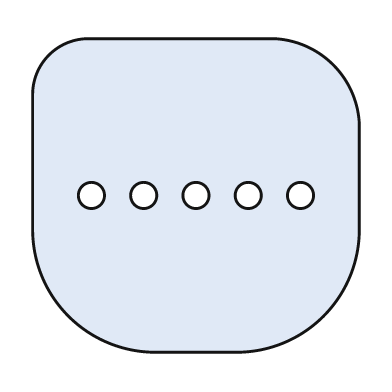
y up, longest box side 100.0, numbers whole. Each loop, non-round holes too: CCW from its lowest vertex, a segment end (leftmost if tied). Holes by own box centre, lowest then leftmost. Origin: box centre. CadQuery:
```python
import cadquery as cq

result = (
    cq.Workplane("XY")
    .moveTo(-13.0, -48.0)
    .lineTo(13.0, -48.0)
    .threePointArc((39.0, -37.0), (50.0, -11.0))
    .lineTo(50.0, 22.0)
    .threePointArc((42.0, 40.0), (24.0, 48.0))
    .lineTo(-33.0, 48.0)
    .threePointArc((-45.0, 43.0), (-50.0, 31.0))
    .lineTo(-50.0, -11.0)
    .threePointArc((-39.0, -37.0), (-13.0, -48.0))
    .close()
    .moveTo(-32.0, 0.0)
    .circle(4.0)
    .moveTo(-16.0, 0.0)
    .circle(4.0)
    .moveTo(0.0, 0.0)
    .circle(4.0)
    .moveTo(16.0, 0.0)
    .circle(4.0)
    .moveTo(32.0, 0.0)
    .circle(4.0)
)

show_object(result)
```